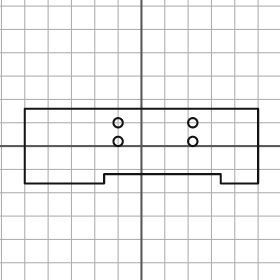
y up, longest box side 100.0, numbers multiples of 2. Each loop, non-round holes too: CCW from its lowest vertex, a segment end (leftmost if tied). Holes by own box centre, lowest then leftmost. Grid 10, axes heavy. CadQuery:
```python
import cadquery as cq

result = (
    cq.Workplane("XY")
    .moveTo(-50.0, -16.0)
    .lineTo(-16.0, -16.0)
    .lineTo(-16.0, -12.0)
    .lineTo(34.0, -12.0)
    .lineTo(34.0, -16.0)
    .lineTo(50.0, -16.0)
    .lineTo(50.0, 16.0)
    .lineTo(-50.0, 16.0)
    .close()
    .moveTo(-10.0, 2.0)
    .circle(2.0)
    .moveTo(22.0, 2.0)
    .circle(2.0)
    .moveTo(-10.0, 10.0)
    .circle(2.0)
    .moveTo(22.0, 10.0)
    .circle(2.0)
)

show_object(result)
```